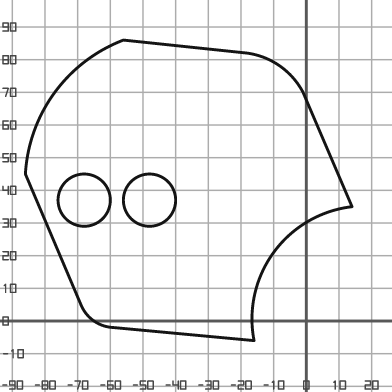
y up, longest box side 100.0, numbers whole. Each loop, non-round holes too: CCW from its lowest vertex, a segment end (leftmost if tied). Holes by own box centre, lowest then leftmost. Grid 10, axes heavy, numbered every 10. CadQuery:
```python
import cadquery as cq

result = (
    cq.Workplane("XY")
    .moveTo(-16.0, -6.0)
    .threePointArc((-10.0, 21.0), (14.0, 35.0))
    .lineTo(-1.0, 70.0)
    .threePointArc((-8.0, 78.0), (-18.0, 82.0))
    .lineTo(-56.0, 86.0)
    .threePointArc((-77.0, 70.0), (-86.0, 45.0))
    .lineTo(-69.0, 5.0)
    .threePointArc((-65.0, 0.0), (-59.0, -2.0))
    .close()
    .moveTo(-68.0, 37.0)
    .circle(8.0)
    .moveTo(-48.0, 37.0)
    .circle(8.0)
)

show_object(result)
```